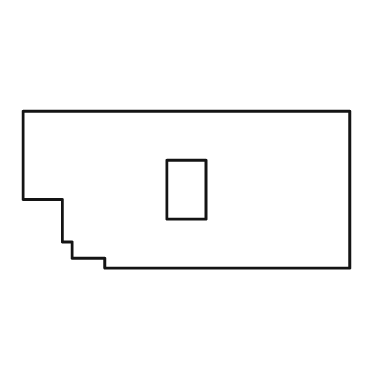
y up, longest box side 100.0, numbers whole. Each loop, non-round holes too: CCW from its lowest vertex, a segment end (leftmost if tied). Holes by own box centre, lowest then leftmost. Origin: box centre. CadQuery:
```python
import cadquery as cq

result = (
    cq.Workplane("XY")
    .moveTo(-25.0, -24.0)
    .lineTo(50.0, -24.0)
    .lineTo(50.0, 24.0)
    .lineTo(-50.0, 24.0)
    .lineTo(-50.0, -3.0)
    .lineTo(-38.0, -3.0)
    .lineTo(-38.0, -16.0)
    .lineTo(-35.0, -16.0)
    .lineTo(-35.0, -21.0)
    .lineTo(-25.0, -21.0)
    .close()
    .moveTo(-6.0, -9.0)
    .lineTo(6.0, -9.0)
    .lineTo(6.0, 9.0)
    .lineTo(-6.0, 9.0)
    .close()
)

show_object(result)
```